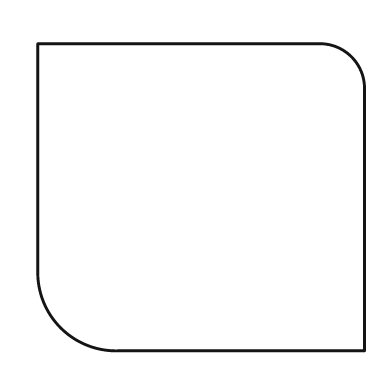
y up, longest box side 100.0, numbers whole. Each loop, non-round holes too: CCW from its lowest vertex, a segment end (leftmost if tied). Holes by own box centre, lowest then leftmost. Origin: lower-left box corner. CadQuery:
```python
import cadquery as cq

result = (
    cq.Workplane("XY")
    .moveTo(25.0, 0.0)
    .lineTo(100.0, 0.0)
    .lineTo(100.0, 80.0)
    .threePointArc((96.0, 90.0), (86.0, 94.0))
    .lineTo(0.0, 94.0)
    .lineTo(0.0, 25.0)
    .threePointArc((7.0, 7.0), (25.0, 0.0))
    .close()
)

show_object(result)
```